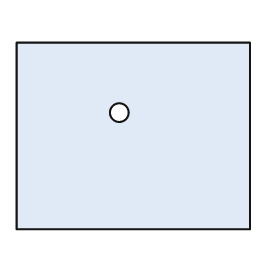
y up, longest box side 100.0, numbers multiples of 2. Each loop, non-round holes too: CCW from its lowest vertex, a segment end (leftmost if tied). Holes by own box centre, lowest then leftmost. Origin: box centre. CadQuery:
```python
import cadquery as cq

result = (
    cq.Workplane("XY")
    .moveTo(-50.0, -40.0)
    .lineTo(50.0, -40.0)
    .lineTo(50.0, 40.0)
    .lineTo(-50.0, 40.0)
    .close()
    .moveTo(-6.0, 10.0)
    .circle(4.0)
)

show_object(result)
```